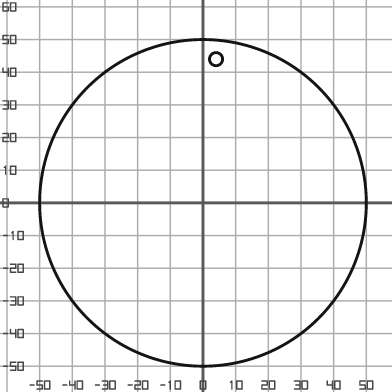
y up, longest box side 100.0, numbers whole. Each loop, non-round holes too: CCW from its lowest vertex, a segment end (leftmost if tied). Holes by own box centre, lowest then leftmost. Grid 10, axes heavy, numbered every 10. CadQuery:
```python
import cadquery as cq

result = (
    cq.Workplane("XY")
    .moveTo(0.0, 0.0)
    .circle(50.0)
    .moveTo(4.0, 44.0)
    .circle(2.0)
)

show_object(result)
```